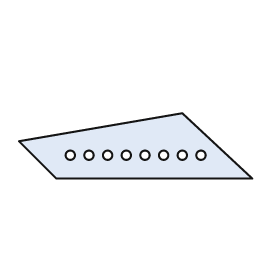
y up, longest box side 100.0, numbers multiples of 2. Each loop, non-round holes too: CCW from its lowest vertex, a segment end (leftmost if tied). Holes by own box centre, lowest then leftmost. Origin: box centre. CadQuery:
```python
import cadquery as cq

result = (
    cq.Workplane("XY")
    .moveTo(-34.0, -14.0)
    .lineTo(50.0, -14.0)
    .lineTo(20.0, 14.0)
    .lineTo(-50.0, 2.0)
    .close()
    .moveTo(-28.0, -4.0)
    .circle(2.0)
    .moveTo(-20.0, -4.0)
    .circle(2.0)
    .moveTo(-12.0, -4.0)
    .circle(2.0)
    .moveTo(-4.0, -4.0)
    .circle(2.0)
    .moveTo(4.0, -4.0)
    .circle(2.0)
    .moveTo(12.0, -4.0)
    .circle(2.0)
    .moveTo(20.0, -4.0)
    .circle(2.0)
    .moveTo(28.0, -4.0)
    .circle(2.0)
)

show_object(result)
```